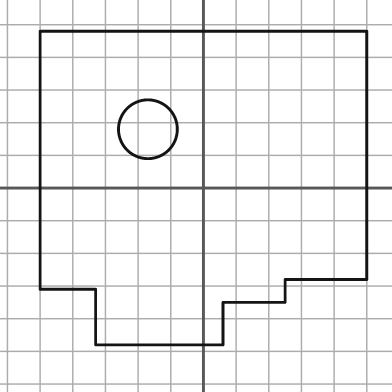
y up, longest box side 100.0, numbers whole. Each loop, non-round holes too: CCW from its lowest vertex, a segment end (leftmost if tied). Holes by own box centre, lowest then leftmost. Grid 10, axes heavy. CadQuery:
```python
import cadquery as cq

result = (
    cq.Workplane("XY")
    .moveTo(-33.0, -48.0)
    .lineTo(6.0, -48.0)
    .lineTo(6.0, -35.0)
    .lineTo(25.0, -35.0)
    .lineTo(25.0, -28.0)
    .lineTo(50.0, -28.0)
    .lineTo(50.0, 48.0)
    .lineTo(-50.0, 48.0)
    .lineTo(-50.0, -31.0)
    .lineTo(-33.0, -31.0)
    .close()
    .moveTo(-17.0, 18.0)
    .circle(9.0)
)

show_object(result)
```